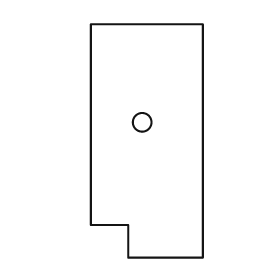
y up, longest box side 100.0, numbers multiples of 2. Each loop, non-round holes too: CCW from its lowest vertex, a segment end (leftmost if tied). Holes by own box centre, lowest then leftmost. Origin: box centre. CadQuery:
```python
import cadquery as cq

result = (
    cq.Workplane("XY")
    .moveTo(-8.0, -50.0)
    .lineTo(24.0, -50.0)
    .lineTo(24.0, 50.0)
    .lineTo(-24.0, 50.0)
    .lineTo(-24.0, -36.0)
    .lineTo(-8.0, -36.0)
    .close()
    .moveTo(-2.0, 8.0)
    .circle(4.0)
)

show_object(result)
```